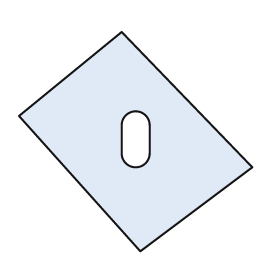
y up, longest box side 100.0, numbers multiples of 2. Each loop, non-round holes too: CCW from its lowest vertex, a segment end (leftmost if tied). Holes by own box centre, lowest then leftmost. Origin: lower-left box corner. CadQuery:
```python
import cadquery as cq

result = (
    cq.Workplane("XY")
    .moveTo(52.0, 0.0)
    .lineTo(100.0, 36.0)
    .lineTo(44.0, 94.0)
    .lineTo(0.0, 58.0)
    .close()
    .moveTo(44.0, 42.0)
    .threePointArc((50.0, 36.0), (56.0, 42.0))
    .lineTo(56.0, 54.0)
    .threePointArc((50.0, 60.0), (44.0, 54.0))
    .close()
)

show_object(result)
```